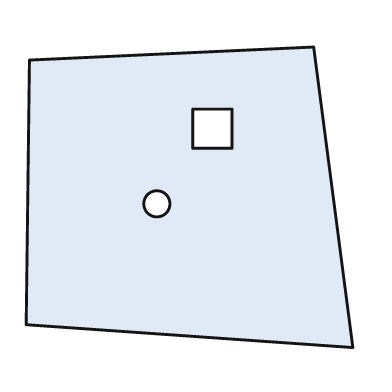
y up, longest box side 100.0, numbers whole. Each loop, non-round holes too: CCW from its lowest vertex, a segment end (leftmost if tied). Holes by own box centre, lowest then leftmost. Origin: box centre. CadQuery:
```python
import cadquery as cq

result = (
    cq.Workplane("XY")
    .moveTo(50.0, -46.0)
    .lineTo(38.0, 46.0)
    .lineTo(-49.0, 42.0)
    .lineTo(-50.0, -39.0)
    .close()
    .moveTo(-10.0, -2.0)
    .circle(4.0)
    .moveTo(1.0, 15.0)
    .lineTo(13.0, 15.0)
    .lineTo(13.0, 27.0)
    .lineTo(1.0, 27.0)
    .close()
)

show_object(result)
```